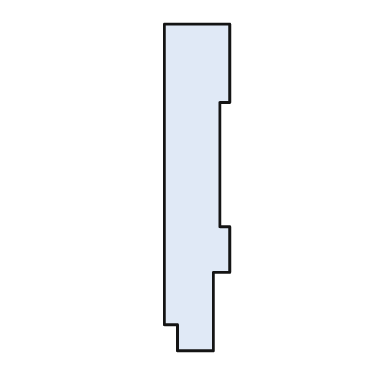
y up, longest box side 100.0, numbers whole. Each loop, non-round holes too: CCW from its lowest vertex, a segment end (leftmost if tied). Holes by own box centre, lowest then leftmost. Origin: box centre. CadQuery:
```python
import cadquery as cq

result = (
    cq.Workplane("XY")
    .moveTo(-6.0, -50.0)
    .lineTo(5.0, -50.0)
    .lineTo(5.0, -26.0)
    .lineTo(10.0, -26.0)
    .lineTo(10.0, -12.0)
    .lineTo(7.0, -12.0)
    .lineTo(7.0, 26.0)
    .lineTo(10.0, 26.0)
    .lineTo(10.0, 50.0)
    .lineTo(-10.0, 50.0)
    .lineTo(-10.0, -42.0)
    .lineTo(-6.0, -42.0)
    .close()
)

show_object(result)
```